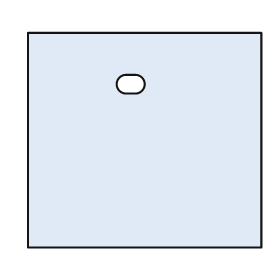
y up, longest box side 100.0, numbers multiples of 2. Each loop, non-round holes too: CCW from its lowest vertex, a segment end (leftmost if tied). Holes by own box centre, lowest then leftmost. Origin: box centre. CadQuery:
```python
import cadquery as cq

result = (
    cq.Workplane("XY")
    .moveTo(-50.0, -46.0)
    .lineTo(50.0, -46.0)
    .lineTo(50.0, 46.0)
    .lineTo(-50.0, 46.0)
    .close()
    .moveTo(-8.0, 20.0)
    .lineTo(-4.0, 20.0)
    .threePointArc((0.0, 24.0), (-4.0, 28.0))
    .lineTo(-8.0, 28.0)
    .threePointArc((-12.0, 24.0), (-8.0, 20.0))
    .close()
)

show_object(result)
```